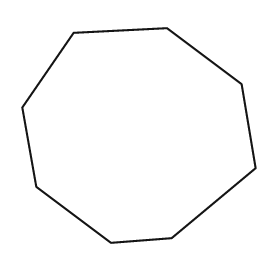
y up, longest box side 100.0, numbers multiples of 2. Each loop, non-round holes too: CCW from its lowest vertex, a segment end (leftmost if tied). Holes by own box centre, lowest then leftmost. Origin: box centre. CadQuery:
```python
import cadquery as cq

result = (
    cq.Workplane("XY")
    .moveTo(-12.0, -46.0)
    .lineTo(14.0, -44.0)
    .lineTo(50.0, -14.0)
    .lineTo(44.0, 22.0)
    .lineTo(12.0, 46.0)
    .lineTo(-28.0, 44.0)
    .lineTo(-50.0, 12.0)
    .lineTo(-44.0, -22.0)
    .close()
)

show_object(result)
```